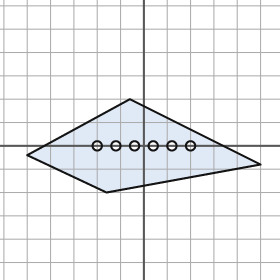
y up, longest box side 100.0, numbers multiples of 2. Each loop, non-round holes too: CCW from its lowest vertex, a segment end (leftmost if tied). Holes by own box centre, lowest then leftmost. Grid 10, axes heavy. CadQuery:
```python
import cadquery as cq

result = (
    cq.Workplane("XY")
    .moveTo(-16.0, -20.0)
    .lineTo(50.0, -8.0)
    .lineTo(-6.0, 20.0)
    .lineTo(-50.0, -4.0)
    .close()
    .moveTo(-20.0, 0.0)
    .circle(2.0)
    .moveTo(-12.0, 0.0)
    .circle(2.0)
    .moveTo(-4.0, 0.0)
    .circle(2.0)
    .moveTo(4.0, 0.0)
    .circle(2.0)
    .moveTo(12.0, 0.0)
    .circle(2.0)
    .moveTo(20.0, 0.0)
    .circle(2.0)
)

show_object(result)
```